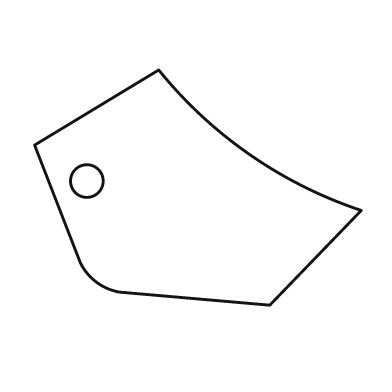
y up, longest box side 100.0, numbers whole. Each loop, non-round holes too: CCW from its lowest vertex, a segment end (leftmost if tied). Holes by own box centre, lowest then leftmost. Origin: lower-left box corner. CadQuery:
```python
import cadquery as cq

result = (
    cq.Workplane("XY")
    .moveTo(72.0, 0.0)
    .lineTo(100.0, 29.0)
    .threePointArc((66.0, 46.0), (38.0, 72.0))
    .lineTo(0.0, 49.0)
    .lineTo(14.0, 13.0)
    .threePointArc((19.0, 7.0), (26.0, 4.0))
    .close()
    .moveTo(16.0, 38.0)
    .circle(5.0)
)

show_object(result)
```